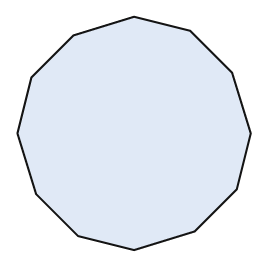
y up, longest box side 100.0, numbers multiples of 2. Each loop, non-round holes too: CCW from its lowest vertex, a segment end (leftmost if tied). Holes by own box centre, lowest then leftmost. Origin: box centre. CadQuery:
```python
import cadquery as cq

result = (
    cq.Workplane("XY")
    .moveTo(0.0, -50.0)
    .lineTo(26.0, -42.0)
    .lineTo(44.0, -24.0)
    .lineTo(50.0, 0.0)
    .lineTo(42.0, 26.0)
    .lineTo(24.0, 44.0)
    .lineTo(0.0, 50.0)
    .lineTo(-26.0, 42.0)
    .lineTo(-44.0, 24.0)
    .lineTo(-50.0, 0.0)
    .lineTo(-42.0, -26.0)
    .lineTo(-24.0, -44.0)
    .close()
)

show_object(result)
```